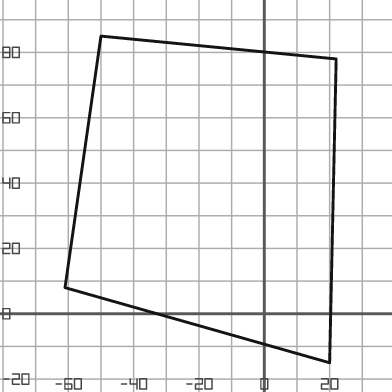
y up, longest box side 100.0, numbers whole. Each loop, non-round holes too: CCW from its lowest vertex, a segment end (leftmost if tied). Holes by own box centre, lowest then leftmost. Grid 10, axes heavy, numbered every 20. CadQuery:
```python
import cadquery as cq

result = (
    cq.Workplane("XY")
    .moveTo(20.0, -15.0)
    .lineTo(22.0, 78.0)
    .lineTo(-50.0, 85.0)
    .lineTo(-61.0, 8.0)
    .close()
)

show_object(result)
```